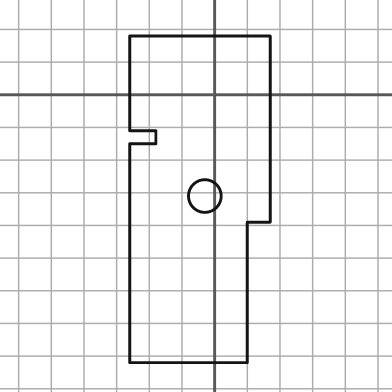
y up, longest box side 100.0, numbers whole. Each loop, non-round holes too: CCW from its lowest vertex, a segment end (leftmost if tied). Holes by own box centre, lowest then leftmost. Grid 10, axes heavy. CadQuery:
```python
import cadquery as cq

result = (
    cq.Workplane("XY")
    .moveTo(-26.0, -82.0)
    .lineTo(10.0, -82.0)
    .lineTo(10.0, -39.0)
    .lineTo(17.0, -39.0)
    .lineTo(17.0, 18.0)
    .lineTo(-26.0, 18.0)
    .lineTo(-26.0, -11.0)
    .lineTo(-18.0, -11.0)
    .lineTo(-18.0, -15.0)
    .lineTo(-26.0, -15.0)
    .close()
    .moveTo(-3.0, -31.0)
    .circle(5.0)
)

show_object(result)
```